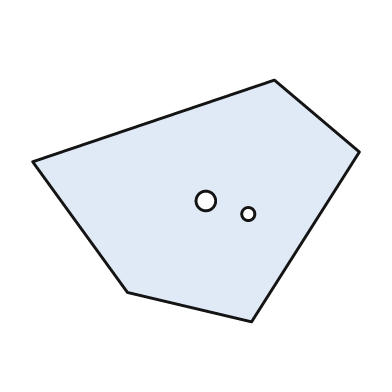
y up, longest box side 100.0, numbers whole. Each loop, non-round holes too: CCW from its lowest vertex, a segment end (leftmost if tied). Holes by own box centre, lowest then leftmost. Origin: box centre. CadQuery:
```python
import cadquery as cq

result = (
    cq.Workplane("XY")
    .moveTo(17.0, -37.0)
    .lineTo(50.0, 15.0)
    .lineTo(24.0, 37.0)
    .lineTo(-50.0, 12.0)
    .lineTo(-21.0, -28.0)
    .close()
    .moveTo(16.0, -4.0)
    .circle(2.0)
    .moveTo(3.0, 0.0)
    .circle(3.0)
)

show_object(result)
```